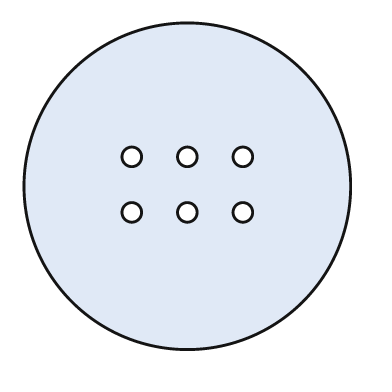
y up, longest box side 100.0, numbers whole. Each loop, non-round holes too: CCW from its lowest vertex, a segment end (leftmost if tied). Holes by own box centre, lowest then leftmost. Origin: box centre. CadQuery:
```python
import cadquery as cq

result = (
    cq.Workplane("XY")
    .moveTo(0.0, 0.0)
    .circle(50.0)
    .moveTo(-17.0, -8.0)
    .circle(3.0)
    .moveTo(0.0, -8.0)
    .circle(3.0)
    .moveTo(17.0, -8.0)
    .circle(3.0)
    .moveTo(-17.0, 9.0)
    .circle(3.0)
    .moveTo(0.0, 9.0)
    .circle(3.0)
    .moveTo(17.0, 9.0)
    .circle(3.0)
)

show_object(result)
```